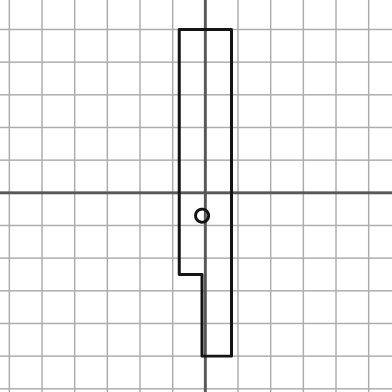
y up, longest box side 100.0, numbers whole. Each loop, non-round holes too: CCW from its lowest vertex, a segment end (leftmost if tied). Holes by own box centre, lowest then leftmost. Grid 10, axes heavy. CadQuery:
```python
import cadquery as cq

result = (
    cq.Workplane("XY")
    .moveTo(-1.0, -50.0)
    .lineTo(8.0, -50.0)
    .lineTo(8.0, 50.0)
    .lineTo(-8.0, 50.0)
    .lineTo(-8.0, -25.0)
    .lineTo(-1.0, -25.0)
    .close()
    .moveTo(-1.0, -7.0)
    .circle(2.0)
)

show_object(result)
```